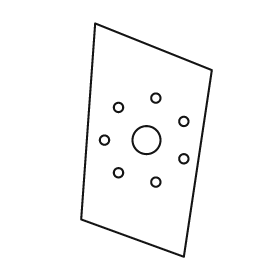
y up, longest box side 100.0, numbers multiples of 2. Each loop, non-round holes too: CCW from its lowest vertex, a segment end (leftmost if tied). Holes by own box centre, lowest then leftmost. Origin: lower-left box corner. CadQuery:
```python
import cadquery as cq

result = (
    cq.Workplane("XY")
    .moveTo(44.0, 0.0)
    .lineTo(56.0, 80.0)
    .lineTo(6.0, 100.0)
    .lineTo(0.0, 16.0)
    .close()
    .moveTo(32.0, 32.0)
    .circle(2.0)
    .moveTo(16.0, 36.0)
    .circle(2.0)
    .moveTo(44.0, 42.0)
    .circle(2.0)
    .moveTo(10.0, 50.0)
    .circle(2.0)
    .moveTo(28.0, 50.0)
    .circle(6.0)
    .moveTo(44.0, 58.0)
    .circle(2.0)
    .moveTo(16.0, 64.0)
    .circle(2.0)
    .moveTo(32.0, 68.0)
    .circle(2.0)
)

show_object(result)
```